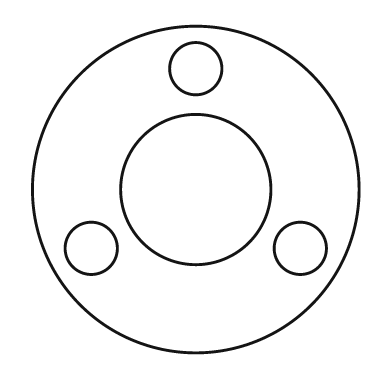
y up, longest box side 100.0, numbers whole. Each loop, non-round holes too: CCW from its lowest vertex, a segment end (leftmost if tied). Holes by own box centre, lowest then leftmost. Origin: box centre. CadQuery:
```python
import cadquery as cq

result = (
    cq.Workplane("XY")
    .moveTo(0.0, 0.0)
    .circle(50.0)
    .moveTo(-32.0, -18.0)
    .circle(8.0)
    .moveTo(32.0, -18.0)
    .circle(8.0)
    .moveTo(0.0, 0.0)
    .circle(23.0)
    .moveTo(0.0, 37.0)
    .circle(8.0)
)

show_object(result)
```